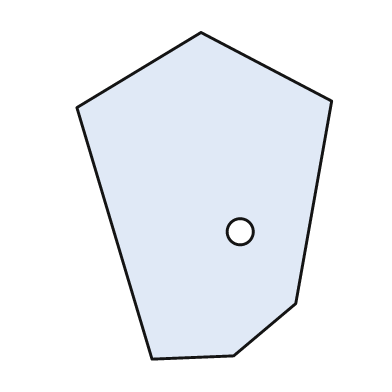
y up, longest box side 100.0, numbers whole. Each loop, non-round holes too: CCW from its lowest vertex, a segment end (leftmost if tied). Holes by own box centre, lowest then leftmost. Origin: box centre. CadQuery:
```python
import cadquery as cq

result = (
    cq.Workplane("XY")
    .moveTo(-16.0, -50.0)
    .lineTo(9.0, -49.0)
    .lineTo(28.0, -33.0)
    .lineTo(39.0, 29.0)
    .lineTo(-1.0, 50.0)
    .lineTo(-39.0, 27.0)
    .close()
    .moveTo(11.0, -11.0)
    .circle(4.0)
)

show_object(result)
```